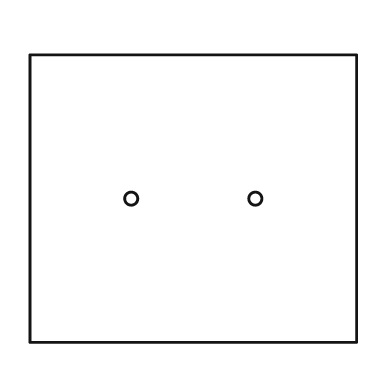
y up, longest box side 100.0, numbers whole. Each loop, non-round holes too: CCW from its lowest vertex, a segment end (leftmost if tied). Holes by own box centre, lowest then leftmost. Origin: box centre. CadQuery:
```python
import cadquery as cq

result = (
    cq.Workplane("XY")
    .moveTo(-50.0, -44.0)
    .lineTo(50.0, -44.0)
    .lineTo(50.0, 44.0)
    .lineTo(-50.0, 44.0)
    .close()
    .moveTo(-19.0, 0.0)
    .circle(2.0)
    .moveTo(19.0, 0.0)
    .circle(2.0)
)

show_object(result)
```